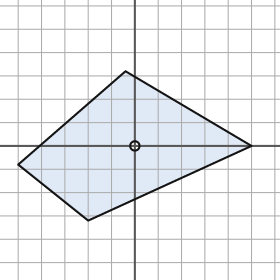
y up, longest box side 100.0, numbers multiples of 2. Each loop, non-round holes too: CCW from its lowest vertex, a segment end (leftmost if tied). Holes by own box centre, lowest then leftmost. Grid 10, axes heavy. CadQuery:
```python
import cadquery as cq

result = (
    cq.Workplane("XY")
    .moveTo(-20.0, -32.0)
    .lineTo(50.0, 0.0)
    .lineTo(-4.0, 32.0)
    .lineTo(-50.0, -8.0)
    .close()
    .moveTo(0.0, 0.0)
    .circle(2.0)
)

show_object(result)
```